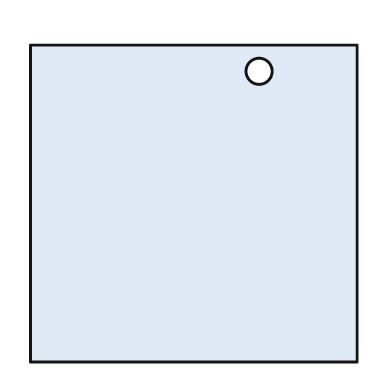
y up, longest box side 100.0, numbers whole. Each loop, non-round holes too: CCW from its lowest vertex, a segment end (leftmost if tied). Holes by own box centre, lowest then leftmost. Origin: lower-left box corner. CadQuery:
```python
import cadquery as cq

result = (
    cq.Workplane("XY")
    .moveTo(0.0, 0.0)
    .lineTo(100.0, 0.0)
    .lineTo(100.0, 97.0)
    .lineTo(0.0, 97.0)
    .close()
    .moveTo(70.0, 89.0)
    .circle(4.0)
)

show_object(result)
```